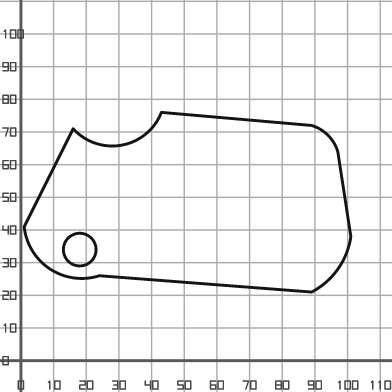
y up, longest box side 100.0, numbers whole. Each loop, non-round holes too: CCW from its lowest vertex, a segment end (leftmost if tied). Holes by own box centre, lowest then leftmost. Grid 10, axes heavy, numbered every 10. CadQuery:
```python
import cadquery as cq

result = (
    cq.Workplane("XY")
    .moveTo(89.0, 21.0)
    .threePointArc((97.0, 28.0), (101.0, 38.0))
    .lineTo(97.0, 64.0)
    .threePointArc((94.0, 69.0), (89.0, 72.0))
    .lineTo(43.0, 76.0)
    .threePointArc((31.0, 66.0), (16.0, 71.0))
    .lineTo(1.0, 41.0)
    .threePointArc((9.0, 28.0), (24.0, 26.0))
    .close()
    .moveTo(18.0, 34.0)
    .circle(5.0)
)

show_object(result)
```